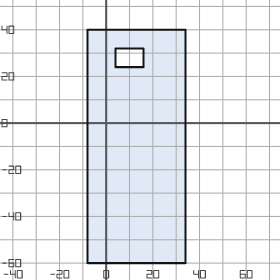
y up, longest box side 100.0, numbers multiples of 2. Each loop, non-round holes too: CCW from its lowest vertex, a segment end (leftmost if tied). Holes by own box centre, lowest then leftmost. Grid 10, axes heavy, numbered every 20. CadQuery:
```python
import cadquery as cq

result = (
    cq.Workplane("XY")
    .moveTo(-8.0, -60.0)
    .lineTo(34.0, -60.0)
    .lineTo(34.0, 40.0)
    .lineTo(-8.0, 40.0)
    .close()
    .moveTo(4.0, 24.0)
    .lineTo(16.0, 24.0)
    .lineTo(16.0, 32.0)
    .lineTo(4.0, 32.0)
    .close()
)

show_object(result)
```